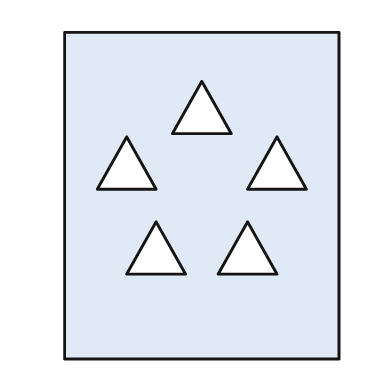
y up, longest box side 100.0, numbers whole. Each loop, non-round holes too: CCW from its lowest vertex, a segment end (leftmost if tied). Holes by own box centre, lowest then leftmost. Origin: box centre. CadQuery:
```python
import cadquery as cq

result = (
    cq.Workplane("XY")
    .moveTo(-42.0, -50.0)
    .lineTo(42.0, -50.0)
    .lineTo(42.0, 50.0)
    .lineTo(-42.0, 50.0)
    .close()
    .moveTo(-23.0, -24.0)
    .lineTo(-5.0, -24.0)
    .lineTo(-14.0, -8.0)
    .close()
    .moveTo(5.0, -24.0)
    .lineTo(23.0, -24.0)
    .lineTo(14.0, -8.0)
    .close()
    .moveTo(-32.0, 2.0)
    .lineTo(-14.0, 2.0)
    .lineTo(-23.0, 18.0)
    .close()
    .moveTo(14.0, 2.0)
    .lineTo(32.0, 2.0)
    .lineTo(23.0, 18.0)
    .close()
    .moveTo(-9.0, 19.0)
    .lineTo(9.0, 19.0)
    .lineTo(0.0, 35.0)
    .close()
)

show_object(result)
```